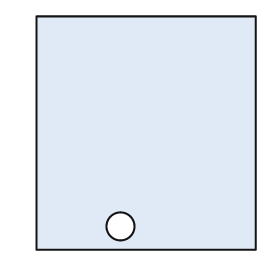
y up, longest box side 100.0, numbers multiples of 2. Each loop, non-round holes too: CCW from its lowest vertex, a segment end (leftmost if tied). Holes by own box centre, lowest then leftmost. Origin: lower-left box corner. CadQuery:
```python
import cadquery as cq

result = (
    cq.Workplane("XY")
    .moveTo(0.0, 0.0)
    .lineTo(94.0, 0.0)
    .lineTo(94.0, 100.0)
    .lineTo(0.0, 100.0)
    .close()
    .moveTo(36.0, 10.0)
    .circle(6.0)
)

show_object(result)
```